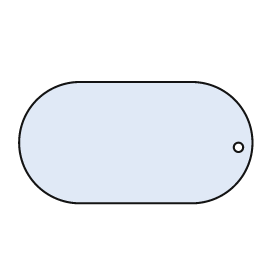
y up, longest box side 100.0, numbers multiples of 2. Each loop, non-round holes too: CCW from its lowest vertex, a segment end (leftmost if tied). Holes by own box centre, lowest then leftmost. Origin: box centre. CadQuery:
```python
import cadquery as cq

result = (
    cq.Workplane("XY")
    .moveTo(-24.0, -26.0)
    .lineTo(24.0, -26.0)
    .threePointArc((50.0, 0.0), (24.0, 26.0))
    .lineTo(-24.0, 26.0)
    .threePointArc((-50.0, 0.0), (-24.0, -26.0))
    .close()
    .moveTo(44.0, -2.0)
    .circle(2.0)
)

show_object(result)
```